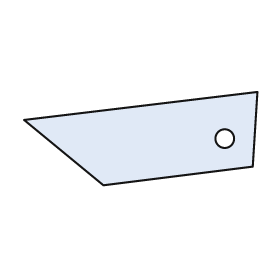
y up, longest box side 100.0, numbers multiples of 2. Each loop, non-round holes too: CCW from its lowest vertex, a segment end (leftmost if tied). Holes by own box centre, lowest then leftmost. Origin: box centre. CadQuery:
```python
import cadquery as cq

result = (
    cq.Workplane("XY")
    .moveTo(-16.0, -20.0)
    .lineTo(48.0, -12.0)
    .lineTo(50.0, 20.0)
    .lineTo(-50.0, 8.0)
    .close()
    .moveTo(36.0, 0.0)
    .circle(4.0)
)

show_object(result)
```